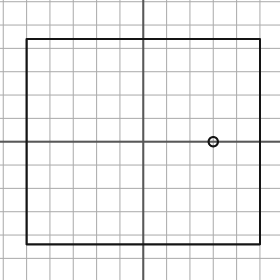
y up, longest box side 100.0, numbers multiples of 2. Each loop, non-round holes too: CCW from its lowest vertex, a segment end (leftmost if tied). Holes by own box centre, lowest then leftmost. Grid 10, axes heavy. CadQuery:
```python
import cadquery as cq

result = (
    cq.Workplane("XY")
    .moveTo(-50.0, -44.0)
    .lineTo(50.0, -44.0)
    .lineTo(50.0, 44.0)
    .lineTo(-50.0, 44.0)
    .close()
    .moveTo(30.0, 0.0)
    .circle(2.0)
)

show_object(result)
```